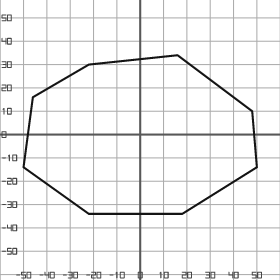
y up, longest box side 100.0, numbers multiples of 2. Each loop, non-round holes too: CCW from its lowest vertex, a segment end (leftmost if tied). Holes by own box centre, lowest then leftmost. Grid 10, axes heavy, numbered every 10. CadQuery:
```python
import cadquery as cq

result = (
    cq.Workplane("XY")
    .moveTo(-22.0, -34.0)
    .lineTo(18.0, -34.0)
    .lineTo(50.0, -14.0)
    .lineTo(48.0, 10.0)
    .lineTo(16.0, 34.0)
    .lineTo(-22.0, 30.0)
    .lineTo(-46.0, 16.0)
    .lineTo(-50.0, -14.0)
    .close()
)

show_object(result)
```